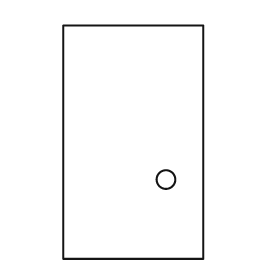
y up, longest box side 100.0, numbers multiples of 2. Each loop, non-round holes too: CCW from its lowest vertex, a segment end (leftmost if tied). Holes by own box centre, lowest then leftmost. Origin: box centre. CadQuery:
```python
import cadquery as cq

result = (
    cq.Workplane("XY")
    .moveTo(-30.0, -50.0)
    .lineTo(30.0, -50.0)
    .lineTo(30.0, 50.0)
    .lineTo(-30.0, 50.0)
    .close()
    .moveTo(14.0, -16.0)
    .circle(4.0)
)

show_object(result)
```